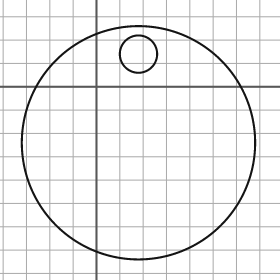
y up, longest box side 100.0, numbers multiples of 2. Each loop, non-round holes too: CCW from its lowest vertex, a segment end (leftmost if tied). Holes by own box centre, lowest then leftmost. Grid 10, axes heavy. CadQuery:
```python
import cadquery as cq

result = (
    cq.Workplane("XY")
    .moveTo(18.0, -24.0)
    .circle(50.0)
    .moveTo(18.0, 14.0)
    .circle(8.0)
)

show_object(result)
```